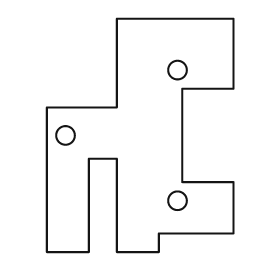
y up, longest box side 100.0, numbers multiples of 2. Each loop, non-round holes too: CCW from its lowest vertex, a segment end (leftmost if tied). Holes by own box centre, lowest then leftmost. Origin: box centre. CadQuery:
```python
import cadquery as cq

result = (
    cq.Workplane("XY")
    .moveTo(-40.0, -50.0)
    .lineTo(-22.0, -50.0)
    .lineTo(-22.0, -10.0)
    .lineTo(-10.0, -10.0)
    .lineTo(-10.0, -50.0)
    .lineTo(8.0, -50.0)
    .lineTo(8.0, -42.0)
    .lineTo(40.0, -42.0)
    .lineTo(40.0, -20.0)
    .lineTo(18.0, -20.0)
    .lineTo(18.0, 20.0)
    .lineTo(40.0, 20.0)
    .lineTo(40.0, 50.0)
    .lineTo(-10.0, 50.0)
    .lineTo(-10.0, 12.0)
    .lineTo(-40.0, 12.0)
    .close()
    .moveTo(16.0, -28.0)
    .circle(4.0)
    .moveTo(-32.0, 0.0)
    .circle(4.0)
    .moveTo(16.0, 28.0)
    .circle(4.0)
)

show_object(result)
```